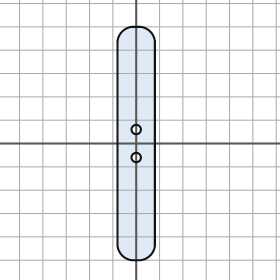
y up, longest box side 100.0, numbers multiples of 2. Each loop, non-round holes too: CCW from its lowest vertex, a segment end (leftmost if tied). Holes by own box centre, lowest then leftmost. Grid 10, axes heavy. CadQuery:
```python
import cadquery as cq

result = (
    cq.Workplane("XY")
    .moveTo(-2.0, -50.0)
    .lineTo(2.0, -50.0)
    .threePointArc((6.0, -48.0), (8.0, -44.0))
    .lineTo(8.0, 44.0)
    .threePointArc((6.0, 48.0), (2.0, 50.0))
    .lineTo(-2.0, 50.0)
    .threePointArc((-6.0, 48.0), (-8.0, 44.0))
    .lineTo(-8.0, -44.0)
    .threePointArc((-6.0, -48.0), (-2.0, -50.0))
    .close()
    .moveTo(0.0, -6.0)
    .circle(2.0)
    .moveTo(0.0, 6.0)
    .circle(2.0)
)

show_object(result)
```